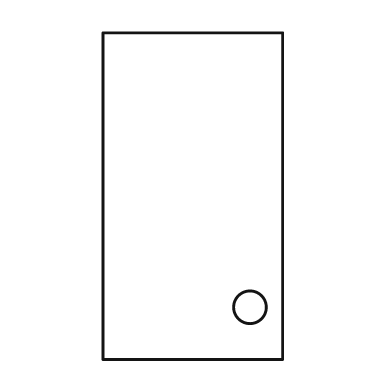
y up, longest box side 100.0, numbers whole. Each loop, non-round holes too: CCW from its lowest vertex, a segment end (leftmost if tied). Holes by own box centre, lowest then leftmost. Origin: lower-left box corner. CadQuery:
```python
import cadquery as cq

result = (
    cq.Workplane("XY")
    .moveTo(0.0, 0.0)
    .lineTo(55.0, 0.0)
    .lineTo(55.0, 100.0)
    .lineTo(0.0, 100.0)
    .close()
    .moveTo(45.0, 16.0)
    .circle(5.0)
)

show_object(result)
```